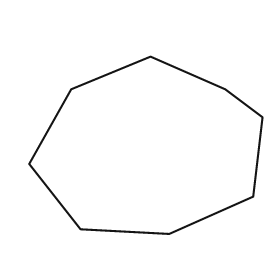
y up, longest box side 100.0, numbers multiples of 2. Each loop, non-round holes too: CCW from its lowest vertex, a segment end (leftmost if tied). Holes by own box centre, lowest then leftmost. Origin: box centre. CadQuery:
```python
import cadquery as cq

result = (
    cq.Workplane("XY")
    .moveTo(10.0, -38.0)
    .lineTo(46.0, -22.0)
    .lineTo(50.0, 12.0)
    .lineTo(34.0, 24.0)
    .lineTo(2.0, 38.0)
    .lineTo(-32.0, 24.0)
    .lineTo(-50.0, -8.0)
    .lineTo(-28.0, -36.0)
    .close()
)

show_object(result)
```